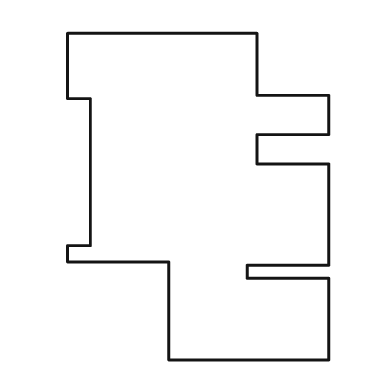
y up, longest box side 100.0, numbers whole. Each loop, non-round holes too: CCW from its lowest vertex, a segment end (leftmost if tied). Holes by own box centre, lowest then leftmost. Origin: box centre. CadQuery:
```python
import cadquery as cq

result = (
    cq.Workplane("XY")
    .moveTo(-9.0, -50.0)
    .lineTo(40.0, -50.0)
    .lineTo(40.0, -25.0)
    .lineTo(15.0, -25.0)
    .lineTo(15.0, -21.0)
    .lineTo(40.0, -21.0)
    .lineTo(40.0, 10.0)
    .lineTo(18.0, 10.0)
    .lineTo(18.0, 19.0)
    .lineTo(40.0, 19.0)
    .lineTo(40.0, 31.0)
    .lineTo(18.0, 31.0)
    .lineTo(18.0, 50.0)
    .lineTo(-40.0, 50.0)
    .lineTo(-40.0, 30.0)
    .lineTo(-33.0, 30.0)
    .lineTo(-33.0, -15.0)
    .lineTo(-40.0, -15.0)
    .lineTo(-40.0, -20.0)
    .lineTo(-9.0, -20.0)
    .close()
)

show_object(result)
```